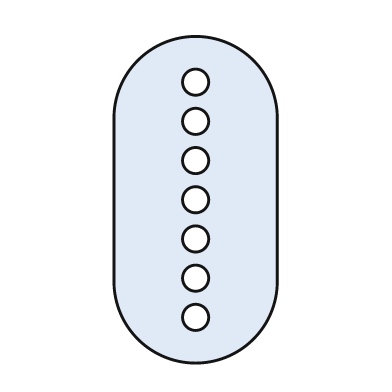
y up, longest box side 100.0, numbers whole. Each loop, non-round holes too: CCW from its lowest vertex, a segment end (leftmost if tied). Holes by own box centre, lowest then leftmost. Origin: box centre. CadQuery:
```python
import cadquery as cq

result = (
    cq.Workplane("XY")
    .moveTo(-25.0, -25.0)
    .threePointArc((0.0, -50.0), (25.0, -25.0))
    .lineTo(25.0, 25.0)
    .threePointArc((0.0, 50.0), (-25.0, 25.0))
    .close()
    .moveTo(0.0, -36.0)
    .circle(4.0)
    .moveTo(0.0, -24.0)
    .circle(4.0)
    .moveTo(0.0, -12.0)
    .circle(4.0)
    .moveTo(0.0, 0.0)
    .circle(4.0)
    .moveTo(0.0, 12.0)
    .circle(4.0)
    .moveTo(0.0, 24.0)
    .circle(4.0)
    .moveTo(0.0, 36.0)
    .circle(4.0)
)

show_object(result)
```